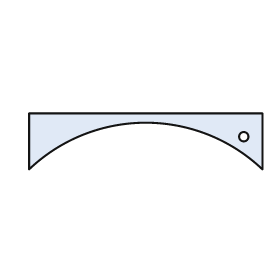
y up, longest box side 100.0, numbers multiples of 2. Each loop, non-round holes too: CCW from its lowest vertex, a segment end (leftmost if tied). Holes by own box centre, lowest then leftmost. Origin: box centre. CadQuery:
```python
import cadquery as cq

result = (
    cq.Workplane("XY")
    .moveTo(-50.0, -12.0)
    .threePointArc((0.0, 8.0), (50.0, -12.0))
    .lineTo(50.0, 12.0)
    .lineTo(-50.0, 12.0)
    .close()
    .moveTo(42.0, 2.0)
    .circle(2.0)
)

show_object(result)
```